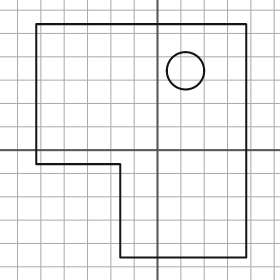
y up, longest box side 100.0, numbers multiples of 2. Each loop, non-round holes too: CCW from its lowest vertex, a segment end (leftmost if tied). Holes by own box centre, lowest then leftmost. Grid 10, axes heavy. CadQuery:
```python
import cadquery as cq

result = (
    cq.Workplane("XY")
    .moveTo(-16.0, -46.0)
    .lineTo(38.0, -46.0)
    .lineTo(38.0, 54.0)
    .lineTo(-52.0, 54.0)
    .lineTo(-52.0, -6.0)
    .lineTo(-16.0, -6.0)
    .close()
    .moveTo(12.0, 34.0)
    .circle(8.0)
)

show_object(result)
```